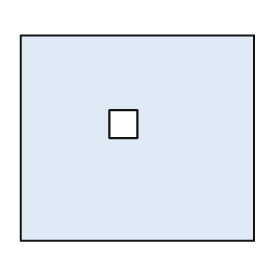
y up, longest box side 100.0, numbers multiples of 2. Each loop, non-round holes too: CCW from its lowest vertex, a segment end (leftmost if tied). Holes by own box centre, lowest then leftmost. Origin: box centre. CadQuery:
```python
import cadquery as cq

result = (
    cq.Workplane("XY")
    .moveTo(-50.0, -44.0)
    .lineTo(50.0, -44.0)
    .lineTo(50.0, 44.0)
    .lineTo(-50.0, 44.0)
    .close()
    .moveTo(-12.0, 0.0)
    .lineTo(0.0, 0.0)
    .lineTo(0.0, 12.0)
    .lineTo(-12.0, 12.0)
    .close()
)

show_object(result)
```